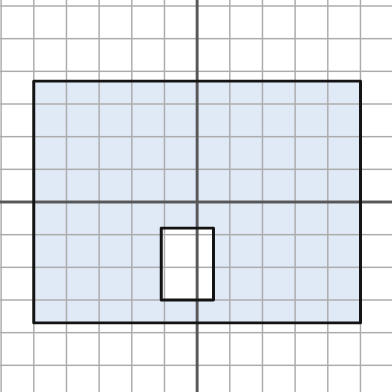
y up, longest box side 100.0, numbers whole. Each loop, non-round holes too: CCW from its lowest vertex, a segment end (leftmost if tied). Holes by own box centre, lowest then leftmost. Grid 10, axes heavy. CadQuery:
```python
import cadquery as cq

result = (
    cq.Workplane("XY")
    .moveTo(-50.0, -37.0)
    .lineTo(50.0, -37.0)
    .lineTo(50.0, 37.0)
    .lineTo(-50.0, 37.0)
    .close()
    .moveTo(-11.0, -30.0)
    .lineTo(5.0, -30.0)
    .lineTo(5.0, -8.0)
    .lineTo(-11.0, -8.0)
    .close()
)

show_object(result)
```